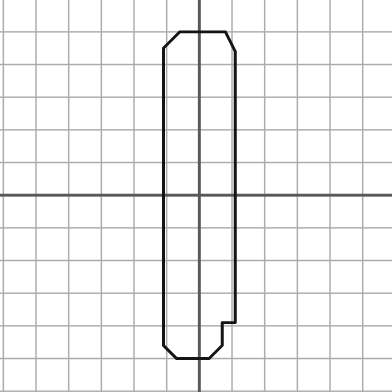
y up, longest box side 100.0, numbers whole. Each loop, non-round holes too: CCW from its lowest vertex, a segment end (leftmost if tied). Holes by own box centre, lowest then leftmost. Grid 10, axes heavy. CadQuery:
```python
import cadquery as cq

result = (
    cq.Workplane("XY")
    .moveTo(-7.0, -50.0)
    .lineTo(3.0, -50.0)
    .lineTo(7.0, -46.0)
    .lineTo(7.0, -39.0)
    .lineTo(11.0, -39.0)
    .lineTo(11.0, 44.0)
    .lineTo(8.0, 50.0)
    .lineTo(-6.0, 50.0)
    .lineTo(-11.0, 45.0)
    .lineTo(-11.0, -46.0)
    .close()
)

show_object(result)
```